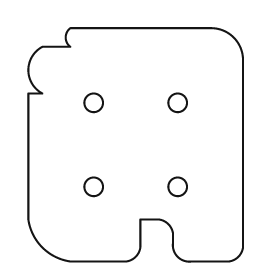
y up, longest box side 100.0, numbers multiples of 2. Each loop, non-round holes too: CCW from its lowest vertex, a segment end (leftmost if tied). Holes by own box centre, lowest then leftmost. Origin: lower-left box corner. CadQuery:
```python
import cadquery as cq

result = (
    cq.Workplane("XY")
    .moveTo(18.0, 0.0)
    .lineTo(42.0, 0.0)
    .threePointArc((46.0, 2.0), (48.0, 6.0))
    .lineTo(48.0, 18.0)
    .lineTo(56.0, 18.0)
    .threePointArc((60.0, 16.0), (62.0, 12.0))
    .lineTo(62.0, 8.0)
    .threePointArc((64.0, 2.0), (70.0, 0.0))
    .lineTo(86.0, 0.0)
    .threePointArc((90.0, 2.0), (92.0, 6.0))
    .lineTo(92.0, 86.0)
    .threePointArc((88.0, 96.0), (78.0, 100.0))
    .lineTo(18.0, 100.0)
    .threePointArc((16.0, 96.0), (18.0, 92.0))
    .lineTo(6.0, 92.0)
    .threePointArc((0.0, 82.0), (6.0, 72.0))
    .lineTo(0.0, 72.0)
    .lineTo(0.0, 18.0)
    .threePointArc((6.0, 6.0), (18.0, 0.0))
    .close()
    .moveTo(28.0, 32.0)
    .circle(4.0)
    .moveTo(64.0, 32.0)
    .circle(4.0)
    .moveTo(28.0, 68.0)
    .circle(4.0)
    .moveTo(64.0, 68.0)
    .circle(4.0)
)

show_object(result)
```